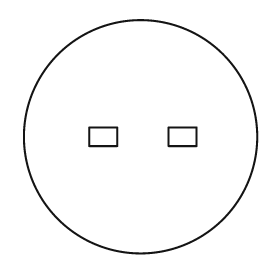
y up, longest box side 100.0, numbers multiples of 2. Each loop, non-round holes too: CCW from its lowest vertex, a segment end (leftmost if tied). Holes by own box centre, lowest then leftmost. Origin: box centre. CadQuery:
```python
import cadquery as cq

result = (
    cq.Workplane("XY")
    .moveTo(0.0, 0.0)
    .circle(50.0)
    .moveTo(-22.0, -4.0)
    .lineTo(-10.0, -4.0)
    .lineTo(-10.0, 4.0)
    .lineTo(-22.0, 4.0)
    .close()
    .moveTo(12.0, -4.0)
    .lineTo(24.0, -4.0)
    .lineTo(24.0, 4.0)
    .lineTo(12.0, 4.0)
    .close()
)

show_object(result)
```